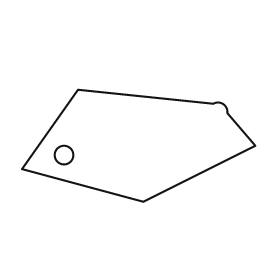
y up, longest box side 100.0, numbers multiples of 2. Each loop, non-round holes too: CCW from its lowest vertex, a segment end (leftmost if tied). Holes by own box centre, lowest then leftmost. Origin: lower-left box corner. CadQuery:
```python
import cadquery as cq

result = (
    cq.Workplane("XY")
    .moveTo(52.0, 0.0)
    .lineTo(100.0, 24.0)
    .lineTo(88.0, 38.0)
    .threePointArc((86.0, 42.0), (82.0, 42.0))
    .lineTo(24.0, 48.0)
    .lineTo(0.0, 14.0)
    .close()
    .moveTo(18.0, 20.0)
    .circle(4.0)
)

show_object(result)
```